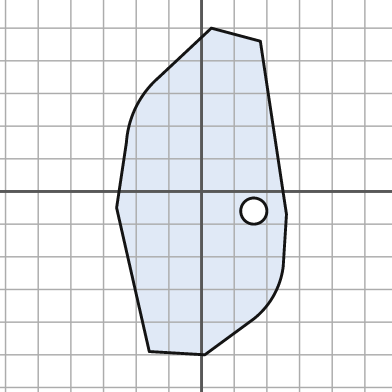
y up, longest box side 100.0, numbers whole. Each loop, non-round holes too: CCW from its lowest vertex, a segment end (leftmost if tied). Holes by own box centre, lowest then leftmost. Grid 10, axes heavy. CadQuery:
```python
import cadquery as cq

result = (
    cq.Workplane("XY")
    .moveTo(1.0, -50.0)
    .lineTo(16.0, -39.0)
    .threePointArc((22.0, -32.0), (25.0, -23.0))
    .lineTo(26.0, -7.0)
    .lineTo(18.0, 46.0)
    .lineTo(3.0, 50.0)
    .lineTo(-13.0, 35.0)
    .threePointArc((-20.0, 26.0), (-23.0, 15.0))
    .lineTo(-26.0, -5.0)
    .lineTo(-16.0, -49.0)
    .close()
    .moveTo(16.0, -6.0)
    .circle(4.0)
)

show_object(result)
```